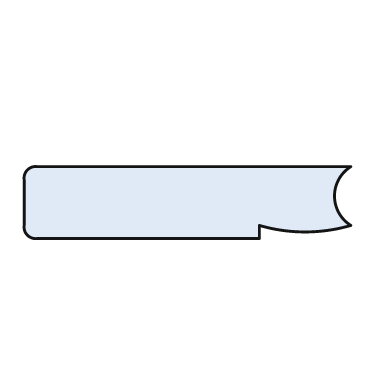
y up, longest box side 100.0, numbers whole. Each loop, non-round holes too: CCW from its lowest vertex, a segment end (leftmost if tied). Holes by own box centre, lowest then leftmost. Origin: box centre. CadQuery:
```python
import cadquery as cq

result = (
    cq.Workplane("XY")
    .moveTo(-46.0, -11.0)
    .lineTo(22.0, -11.0)
    .lineTo(22.0, -7.0)
    .threePointArc((36.0, -9.0), (50.0, -7.0))
    .threePointArc((45.0, 2.0), (50.0, 11.0))
    .lineTo(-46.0, 11.0)
    .threePointArc((-49.0, 10.0), (-50.0, 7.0))
    .lineTo(-50.0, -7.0)
    .threePointArc((-49.0, -10.0), (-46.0, -11.0))
    .close()
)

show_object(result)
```